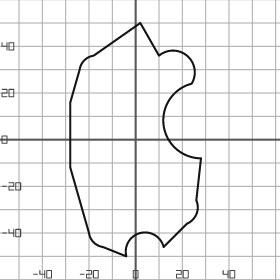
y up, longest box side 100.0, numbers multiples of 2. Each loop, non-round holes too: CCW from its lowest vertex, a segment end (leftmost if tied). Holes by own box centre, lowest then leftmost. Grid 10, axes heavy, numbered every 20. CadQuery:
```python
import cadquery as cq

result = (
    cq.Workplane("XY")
    .moveTo(-4.0, -50.0)
    .threePointArc((2.0, -40.0), (12.0, -46.0))
    .lineTo(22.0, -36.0)
    .threePointArc((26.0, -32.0), (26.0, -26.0))
    .lineTo(28.0, -8.0)
    .threePointArc((12.0, 6.0), (24.0, 24.0))
    .threePointArc((22.0, 36.0), (10.0, 36.0))
    .lineTo(2.0, 50.0)
    .lineTo(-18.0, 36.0)
    .threePointArc((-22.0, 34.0), (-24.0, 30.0))
    .lineTo(-28.0, 16.0)
    .lineTo(-28.0, -12.0)
    .lineTo(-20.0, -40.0)
    .threePointArc((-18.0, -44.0), (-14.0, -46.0))
    .close()
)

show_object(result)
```